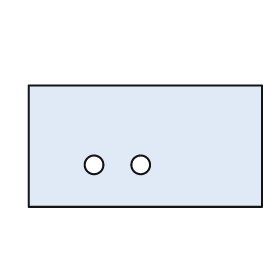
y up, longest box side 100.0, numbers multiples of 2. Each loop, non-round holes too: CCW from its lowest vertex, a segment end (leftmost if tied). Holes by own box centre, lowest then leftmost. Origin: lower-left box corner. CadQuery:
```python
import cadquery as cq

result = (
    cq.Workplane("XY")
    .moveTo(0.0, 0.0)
    .lineTo(100.0, 0.0)
    .lineTo(100.0, 52.0)
    .lineTo(0.0, 52.0)
    .close()
    .moveTo(28.0, 18.0)
    .circle(4.0)
    .moveTo(48.0, 18.0)
    .circle(4.0)
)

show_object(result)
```